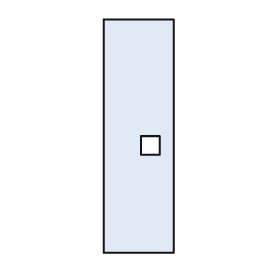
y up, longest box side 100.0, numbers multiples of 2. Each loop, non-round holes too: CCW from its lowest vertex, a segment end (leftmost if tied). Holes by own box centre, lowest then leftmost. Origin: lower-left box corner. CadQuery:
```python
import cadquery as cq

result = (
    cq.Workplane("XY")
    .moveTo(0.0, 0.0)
    .lineTo(30.0, 0.0)
    .lineTo(30.0, 100.0)
    .lineTo(0.0, 100.0)
    .close()
    .moveTo(16.0, 42.0)
    .lineTo(24.0, 42.0)
    .lineTo(24.0, 50.0)
    .lineTo(16.0, 50.0)
    .close()
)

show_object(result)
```